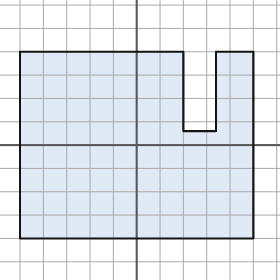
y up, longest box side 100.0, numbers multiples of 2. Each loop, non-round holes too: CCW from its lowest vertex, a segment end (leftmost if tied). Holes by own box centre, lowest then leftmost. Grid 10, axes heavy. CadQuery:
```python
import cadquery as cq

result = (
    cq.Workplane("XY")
    .moveTo(-50.0, -40.0)
    .lineTo(50.0, -40.0)
    .lineTo(50.0, 40.0)
    .lineTo(34.0, 40.0)
    .lineTo(34.0, 6.0)
    .lineTo(20.0, 6.0)
    .lineTo(20.0, 40.0)
    .lineTo(-50.0, 40.0)
    .close()
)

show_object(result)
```